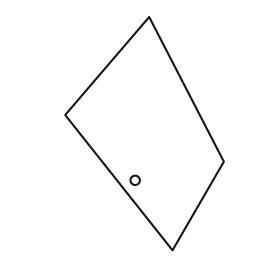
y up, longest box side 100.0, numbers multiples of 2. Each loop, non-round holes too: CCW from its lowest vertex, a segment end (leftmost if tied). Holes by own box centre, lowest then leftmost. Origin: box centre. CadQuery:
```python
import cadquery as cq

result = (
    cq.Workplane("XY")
    .moveTo(12.0, -50.0)
    .lineTo(34.0, -12.0)
    .lineTo(2.0, 50.0)
    .lineTo(-34.0, 8.0)
    .close()
    .moveTo(-4.0, -20.0)
    .circle(2.0)
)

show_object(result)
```